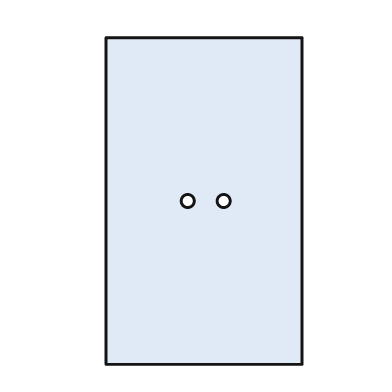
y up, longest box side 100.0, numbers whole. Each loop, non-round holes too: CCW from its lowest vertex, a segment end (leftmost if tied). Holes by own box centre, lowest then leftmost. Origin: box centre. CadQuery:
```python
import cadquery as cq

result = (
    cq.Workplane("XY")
    .moveTo(-30.0, -50.0)
    .lineTo(30.0, -50.0)
    .lineTo(30.0, 50.0)
    .lineTo(-30.0, 50.0)
    .close()
    .moveTo(-5.0, 0.0)
    .circle(2.0)
    .moveTo(6.0, 0.0)
    .circle(2.0)
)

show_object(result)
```